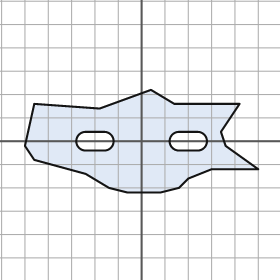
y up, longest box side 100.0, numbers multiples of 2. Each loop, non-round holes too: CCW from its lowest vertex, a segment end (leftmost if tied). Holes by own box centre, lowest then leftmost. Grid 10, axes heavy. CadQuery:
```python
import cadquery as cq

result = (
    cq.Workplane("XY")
    .moveTo(-6.0, -22.0)
    .lineTo(8.0, -22.0)
    .lineTo(16.0, -20.0)
    .lineTo(20.0, -16.0)
    .lineTo(30.0, -12.0)
    .lineTo(50.0, -12.0)
    .lineTo(36.0, -2.0)
    .lineTo(34.0, 4.0)
    .lineTo(42.0, 16.0)
    .lineTo(14.0, 16.0)
    .lineTo(4.0, 22.0)
    .lineTo(-18.0, 14.0)
    .lineTo(-46.0, 16.0)
    .lineTo(-50.0, -2.0)
    .lineTo(-46.0, -8.0)
    .lineTo(-24.0, -14.0)
    .lineTo(-14.0, -20.0)
    .close()
    .moveTo(-24.0, -4.0)
    .lineTo(-16.0, -4.0)
    .threePointArc((-12.0, 0.0), (-16.0, 4.0))
    .lineTo(-24.0, 4.0)
    .threePointArc((-28.0, 0.0), (-24.0, -4.0))
    .close()
    .moveTo(16.0, -4.0)
    .lineTo(24.0, -4.0)
    .threePointArc((28.0, 0.0), (24.0, 4.0))
    .lineTo(16.0, 4.0)
    .threePointArc((12.0, 0.0), (16.0, -4.0))
    .close()
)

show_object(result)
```